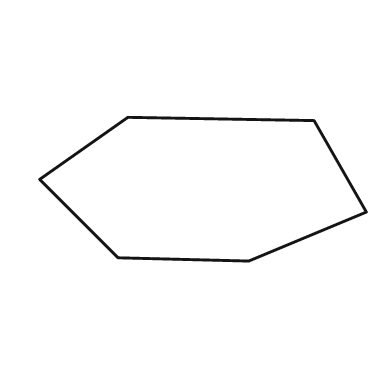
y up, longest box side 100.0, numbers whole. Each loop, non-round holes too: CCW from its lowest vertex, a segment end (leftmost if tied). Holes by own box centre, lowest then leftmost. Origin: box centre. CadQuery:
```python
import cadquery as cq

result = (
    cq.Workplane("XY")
    .moveTo(14.0, -22.0)
    .lineTo(50.0, -7.0)
    .lineTo(34.0, 21.0)
    .lineTo(-23.0, 22.0)
    .lineTo(-50.0, 3.0)
    .lineTo(-26.0, -21.0)
    .close()
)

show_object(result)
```